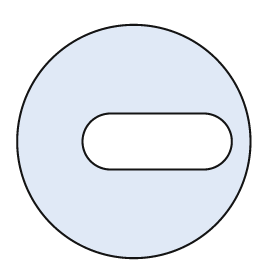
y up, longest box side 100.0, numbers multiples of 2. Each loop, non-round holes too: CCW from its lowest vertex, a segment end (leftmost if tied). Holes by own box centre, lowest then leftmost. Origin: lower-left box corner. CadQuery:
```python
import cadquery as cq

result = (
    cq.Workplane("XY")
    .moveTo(50.0, 50.0)
    .circle(50.0)
    .moveTo(40.0, 38.0)
    .lineTo(80.0, 38.0)
    .threePointArc((92.0, 50.0), (80.0, 62.0))
    .lineTo(40.0, 62.0)
    .threePointArc((28.0, 50.0), (40.0, 38.0))
    .close()
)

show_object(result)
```